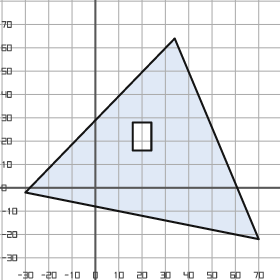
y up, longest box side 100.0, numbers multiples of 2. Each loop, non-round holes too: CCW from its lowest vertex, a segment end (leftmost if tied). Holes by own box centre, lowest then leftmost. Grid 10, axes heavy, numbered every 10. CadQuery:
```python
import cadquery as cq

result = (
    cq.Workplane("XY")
    .moveTo(70.0, -22.0)
    .lineTo(34.0, 64.0)
    .lineTo(-30.0, -2.0)
    .close()
    .moveTo(16.0, 16.0)
    .lineTo(24.0, 16.0)
    .lineTo(24.0, 28.0)
    .lineTo(16.0, 28.0)
    .close()
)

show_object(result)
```